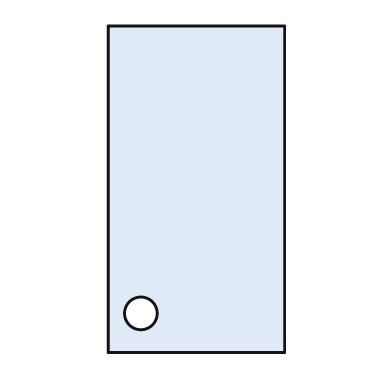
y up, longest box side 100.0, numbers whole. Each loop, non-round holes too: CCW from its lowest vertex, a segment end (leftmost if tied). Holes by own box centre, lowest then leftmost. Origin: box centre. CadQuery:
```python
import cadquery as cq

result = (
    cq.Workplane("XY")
    .moveTo(-27.0, -50.0)
    .lineTo(27.0, -50.0)
    .lineTo(27.0, 50.0)
    .lineTo(-27.0, 50.0)
    .close()
    .moveTo(-17.0, -38.0)
    .circle(5.0)
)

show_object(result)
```